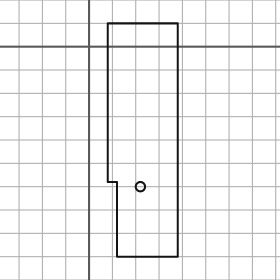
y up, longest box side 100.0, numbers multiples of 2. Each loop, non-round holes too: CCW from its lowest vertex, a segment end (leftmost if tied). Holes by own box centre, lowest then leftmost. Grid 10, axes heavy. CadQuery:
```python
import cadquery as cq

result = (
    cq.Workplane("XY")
    .moveTo(12.0, -90.0)
    .lineTo(38.0, -90.0)
    .lineTo(38.0, 10.0)
    .lineTo(8.0, 10.0)
    .lineTo(8.0, -58.0)
    .lineTo(12.0, -58.0)
    .close()
    .moveTo(22.0, -60.0)
    .circle(2.0)
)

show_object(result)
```